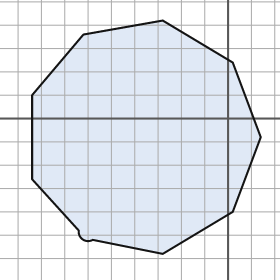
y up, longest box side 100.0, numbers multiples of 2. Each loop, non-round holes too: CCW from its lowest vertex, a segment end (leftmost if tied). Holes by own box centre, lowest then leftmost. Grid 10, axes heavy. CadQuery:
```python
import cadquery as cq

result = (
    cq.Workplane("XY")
    .moveTo(-28.0, -58.0)
    .lineTo(2.0, -40.0)
    .lineTo(14.0, -8.0)
    .lineTo(2.0, 24.0)
    .lineTo(-28.0, 42.0)
    .lineTo(-62.0, 36.0)
    .lineTo(-84.0, 10.0)
    .lineTo(-84.0, -26.0)
    .lineTo(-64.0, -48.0)
    .threePointArc((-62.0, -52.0), (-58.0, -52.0))
    .close()
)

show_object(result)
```